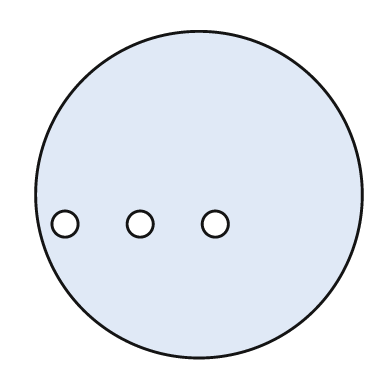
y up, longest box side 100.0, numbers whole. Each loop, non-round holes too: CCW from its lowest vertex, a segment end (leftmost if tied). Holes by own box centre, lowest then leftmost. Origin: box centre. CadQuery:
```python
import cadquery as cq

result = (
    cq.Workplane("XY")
    .moveTo(0.0, 0.0)
    .circle(50.0)
    .moveTo(-41.0, -9.0)
    .circle(4.0)
    .moveTo(-18.0, -9.0)
    .circle(4.0)
    .moveTo(5.0, -9.0)
    .circle(4.0)
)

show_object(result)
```